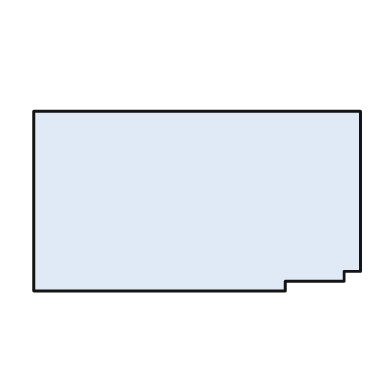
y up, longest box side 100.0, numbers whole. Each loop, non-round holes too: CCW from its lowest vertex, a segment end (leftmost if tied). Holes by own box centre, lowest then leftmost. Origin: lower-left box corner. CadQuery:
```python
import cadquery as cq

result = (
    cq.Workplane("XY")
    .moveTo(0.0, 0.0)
    .lineTo(77.0, 0.0)
    .lineTo(77.0, 3.0)
    .lineTo(95.0, 3.0)
    .lineTo(95.0, 6.0)
    .lineTo(100.0, 6.0)
    .lineTo(100.0, 55.0)
    .lineTo(0.0, 55.0)
    .close()
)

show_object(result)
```